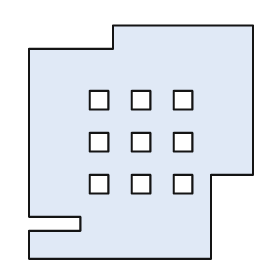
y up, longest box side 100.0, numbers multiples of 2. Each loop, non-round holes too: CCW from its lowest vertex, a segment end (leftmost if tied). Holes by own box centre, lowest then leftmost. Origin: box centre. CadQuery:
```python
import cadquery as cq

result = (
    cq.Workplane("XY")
    .moveTo(-48.0, -50.0)
    .lineTo(30.0, -50.0)
    .lineTo(30.0, -14.0)
    .lineTo(48.0, -14.0)
    .lineTo(48.0, 50.0)
    .lineTo(-12.0, 50.0)
    .lineTo(-12.0, 40.0)
    .lineTo(-48.0, 40.0)
    .lineTo(-48.0, -32.0)
    .lineTo(-26.0, -32.0)
    .lineTo(-26.0, -38.0)
    .lineTo(-48.0, -38.0)
    .close()
    .moveTo(-22.0, -22.0)
    .lineTo(-14.0, -22.0)
    .lineTo(-14.0, -14.0)
    .lineTo(-22.0, -14.0)
    .close()
    .moveTo(-4.0, -22.0)
    .lineTo(4.0, -22.0)
    .lineTo(4.0, -14.0)
    .lineTo(-4.0, -14.0)
    .close()
    .moveTo(14.0, -22.0)
    .lineTo(22.0, -22.0)
    .lineTo(22.0, -14.0)
    .lineTo(14.0, -14.0)
    .close()
    .moveTo(-22.0, -4.0)
    .lineTo(-14.0, -4.0)
    .lineTo(-14.0, 4.0)
    .lineTo(-22.0, 4.0)
    .close()
    .moveTo(-4.0, -4.0)
    .lineTo(4.0, -4.0)
    .lineTo(4.0, 4.0)
    .lineTo(-4.0, 4.0)
    .close()
    .moveTo(14.0, -4.0)
    .lineTo(22.0, -4.0)
    .lineTo(22.0, 4.0)
    .lineTo(14.0, 4.0)
    .close()
    .moveTo(-22.0, 14.0)
    .lineTo(-14.0, 14.0)
    .lineTo(-14.0, 22.0)
    .lineTo(-22.0, 22.0)
    .close()
    .moveTo(-4.0, 14.0)
    .lineTo(4.0, 14.0)
    .lineTo(4.0, 22.0)
    .lineTo(-4.0, 22.0)
    .close()
    .moveTo(14.0, 14.0)
    .lineTo(22.0, 14.0)
    .lineTo(22.0, 22.0)
    .lineTo(14.0, 22.0)
    .close()
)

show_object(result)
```